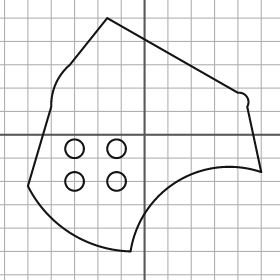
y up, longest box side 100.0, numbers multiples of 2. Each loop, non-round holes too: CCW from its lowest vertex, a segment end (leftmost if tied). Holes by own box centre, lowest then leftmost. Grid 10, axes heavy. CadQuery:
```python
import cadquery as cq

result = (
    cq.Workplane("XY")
    .moveTo(-6.0, -50.0)
    .threePointArc((14.0, -20.0), (50.0, -16.0))
    .lineTo(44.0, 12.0)
    .threePointArc((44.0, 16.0), (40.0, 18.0))
    .lineTo(-16.0, 50.0)
    .lineTo(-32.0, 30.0)
    .threePointArc((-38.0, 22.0), (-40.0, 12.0))
    .lineTo(-50.0, -22.0)
    .threePointArc((-32.0, -42.0), (-6.0, -50.0))
    .close()
    .moveTo(-30.0, -20.0)
    .circle(4.0)
    .moveTo(-12.0, -20.0)
    .circle(4.0)
    .moveTo(-30.0, -6.0)
    .circle(4.0)
    .moveTo(-12.0, -6.0)
    .circle(4.0)
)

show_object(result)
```